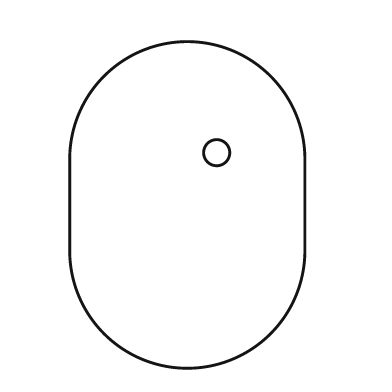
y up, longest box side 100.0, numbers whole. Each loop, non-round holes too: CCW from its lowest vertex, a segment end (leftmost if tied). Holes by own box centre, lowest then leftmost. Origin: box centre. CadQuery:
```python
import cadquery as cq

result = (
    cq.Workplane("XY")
    .moveTo(-36.0, -14.0)
    .threePointArc((0.0, -50.0), (36.0, -14.0))
    .lineTo(36.0, 14.0)
    .threePointArc((0.0, 50.0), (-36.0, 14.0))
    .close()
    .moveTo(9.0, 16.0)
    .circle(4.0)
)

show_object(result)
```